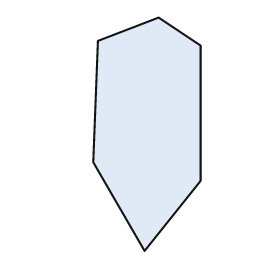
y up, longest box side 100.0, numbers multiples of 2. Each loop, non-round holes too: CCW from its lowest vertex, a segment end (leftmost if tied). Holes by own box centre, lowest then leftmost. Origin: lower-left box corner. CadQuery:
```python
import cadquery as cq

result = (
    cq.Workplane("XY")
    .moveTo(22.0, 0.0)
    .lineTo(46.0, 30.0)
    .lineTo(46.0, 88.0)
    .lineTo(28.0, 100.0)
    .lineTo(2.0, 90.0)
    .lineTo(0.0, 38.0)
    .close()
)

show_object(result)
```